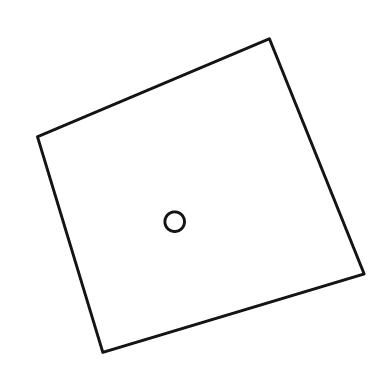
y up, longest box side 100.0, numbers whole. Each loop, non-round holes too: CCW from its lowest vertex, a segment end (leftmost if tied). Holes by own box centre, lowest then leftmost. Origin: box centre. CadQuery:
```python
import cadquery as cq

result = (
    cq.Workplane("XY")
    .moveTo(-30.0, -48.0)
    .lineTo(50.0, -24.0)
    .lineTo(21.0, 48.0)
    .lineTo(-50.0, 18.0)
    .close()
    .moveTo(-8.0, -8.0)
    .circle(3.0)
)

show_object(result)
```